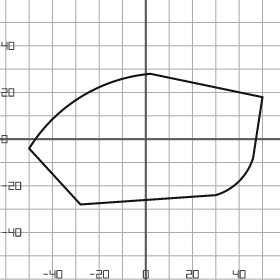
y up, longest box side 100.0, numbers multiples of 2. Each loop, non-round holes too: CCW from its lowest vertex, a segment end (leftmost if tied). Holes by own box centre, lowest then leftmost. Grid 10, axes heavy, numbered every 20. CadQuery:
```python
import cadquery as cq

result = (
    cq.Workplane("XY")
    .moveTo(-28.0, -28.0)
    .lineTo(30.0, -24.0)
    .threePointArc((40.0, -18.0), (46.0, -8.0))
    .lineTo(50.0, 18.0)
    .lineTo(2.0, 28.0)
    .threePointArc((-28.0, 18.0), (-50.0, -4.0))
    .close()
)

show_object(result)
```